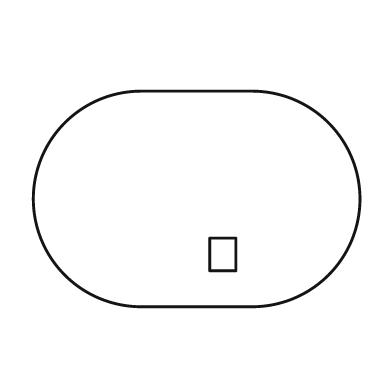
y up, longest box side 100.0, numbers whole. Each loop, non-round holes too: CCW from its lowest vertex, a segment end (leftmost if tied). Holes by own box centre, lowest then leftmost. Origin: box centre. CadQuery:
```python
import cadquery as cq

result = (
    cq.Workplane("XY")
    .moveTo(-17.0, -33.0)
    .lineTo(17.0, -33.0)
    .threePointArc((50.0, 0.0), (17.0, 33.0))
    .lineTo(-17.0, 33.0)
    .threePointArc((-50.0, 0.0), (-17.0, -33.0))
    .close()
    .moveTo(4.0, -22.0)
    .lineTo(12.0, -22.0)
    .lineTo(12.0, -12.0)
    .lineTo(4.0, -12.0)
    .close()
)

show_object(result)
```